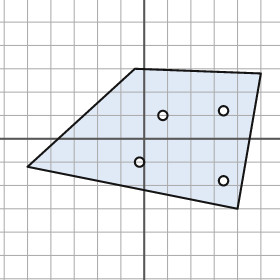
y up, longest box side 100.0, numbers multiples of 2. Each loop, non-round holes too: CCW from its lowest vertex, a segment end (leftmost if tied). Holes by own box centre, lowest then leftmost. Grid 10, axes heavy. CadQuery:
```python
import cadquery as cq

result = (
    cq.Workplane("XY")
    .moveTo(40.0, -30.0)
    .lineTo(50.0, 28.0)
    .lineTo(-4.0, 30.0)
    .lineTo(-50.0, -12.0)
    .close()
    .moveTo(34.0, -18.0)
    .circle(2.0)
    .moveTo(-2.0, -10.0)
    .circle(2.0)
    .moveTo(8.0, 10.0)
    .circle(2.0)
    .moveTo(34.0, 12.0)
    .circle(2.0)
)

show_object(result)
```